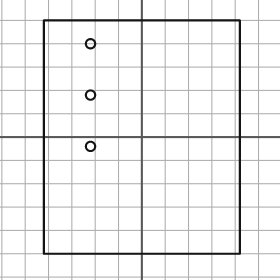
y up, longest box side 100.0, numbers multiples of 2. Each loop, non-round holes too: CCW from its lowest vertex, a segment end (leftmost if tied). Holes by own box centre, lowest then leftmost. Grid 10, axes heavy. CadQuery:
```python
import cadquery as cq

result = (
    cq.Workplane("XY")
    .moveTo(-42.0, -50.0)
    .lineTo(42.0, -50.0)
    .lineTo(42.0, 50.0)
    .lineTo(-42.0, 50.0)
    .close()
    .moveTo(-22.0, -4.0)
    .circle(2.0)
    .moveTo(-22.0, 18.0)
    .circle(2.0)
    .moveTo(-22.0, 40.0)
    .circle(2.0)
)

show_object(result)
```